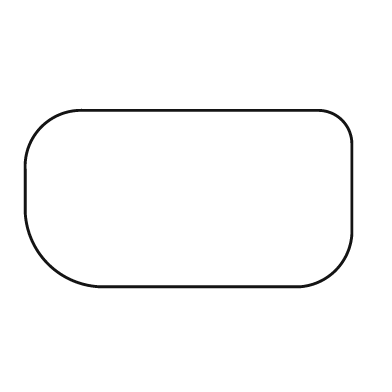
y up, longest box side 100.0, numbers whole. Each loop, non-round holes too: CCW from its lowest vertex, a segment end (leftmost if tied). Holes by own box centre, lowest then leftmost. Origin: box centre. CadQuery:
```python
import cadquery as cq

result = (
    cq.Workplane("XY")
    .moveTo(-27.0, -27.0)
    .lineTo(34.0, -27.0)
    .threePointArc((45.0, -22.0), (50.0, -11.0))
    .lineTo(50.0, 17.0)
    .threePointArc((47.0, 24.0), (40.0, 27.0))
    .lineTo(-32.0, 27.0)
    .threePointArc((-45.0, 22.0), (-50.0, 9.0))
    .lineTo(-50.0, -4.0)
    .threePointArc((-43.0, -20.0), (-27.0, -27.0))
    .close()
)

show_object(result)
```